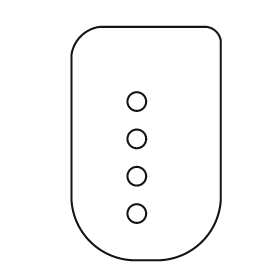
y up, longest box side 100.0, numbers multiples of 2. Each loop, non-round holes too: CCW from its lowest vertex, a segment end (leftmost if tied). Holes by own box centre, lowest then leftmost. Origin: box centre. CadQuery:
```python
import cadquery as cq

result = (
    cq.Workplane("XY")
    .moveTo(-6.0, -50.0)
    .lineTo(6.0, -50.0)
    .threePointArc((24.0, -42.0), (32.0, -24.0))
    .lineTo(32.0, 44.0)
    .threePointArc((30.0, 48.0), (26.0, 50.0))
    .lineTo(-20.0, 50.0)
    .threePointArc((-28.0, 46.0), (-32.0, 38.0))
    .lineTo(-32.0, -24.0)
    .threePointArc((-24.0, -42.0), (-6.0, -50.0))
    .close()
    .moveTo(-4.0, -30.0)
    .circle(4.0)
    .moveTo(-4.0, -14.0)
    .circle(4.0)
    .moveTo(-4.0, 2.0)
    .circle(4.0)
    .moveTo(-4.0, 18.0)
    .circle(4.0)
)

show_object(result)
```